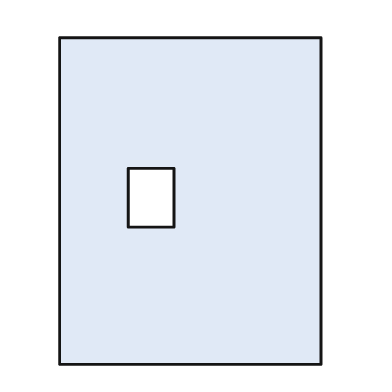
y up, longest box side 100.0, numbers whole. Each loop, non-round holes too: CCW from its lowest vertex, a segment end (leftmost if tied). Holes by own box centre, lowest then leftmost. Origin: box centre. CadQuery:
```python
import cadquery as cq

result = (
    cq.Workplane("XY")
    .moveTo(-40.0, -50.0)
    .lineTo(40.0, -50.0)
    .lineTo(40.0, 50.0)
    .lineTo(-40.0, 50.0)
    .close()
    .moveTo(-19.0, -8.0)
    .lineTo(-5.0, -8.0)
    .lineTo(-5.0, 10.0)
    .lineTo(-19.0, 10.0)
    .close()
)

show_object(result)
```